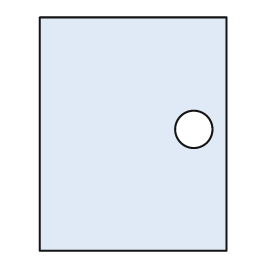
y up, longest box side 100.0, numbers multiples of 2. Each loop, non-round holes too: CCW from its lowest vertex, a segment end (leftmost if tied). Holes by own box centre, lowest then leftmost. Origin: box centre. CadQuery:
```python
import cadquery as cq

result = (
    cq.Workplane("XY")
    .moveTo(-40.0, -50.0)
    .lineTo(40.0, -50.0)
    .lineTo(40.0, 50.0)
    .lineTo(-40.0, 50.0)
    .close()
    .moveTo(26.0, 2.0)
    .circle(8.0)
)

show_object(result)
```